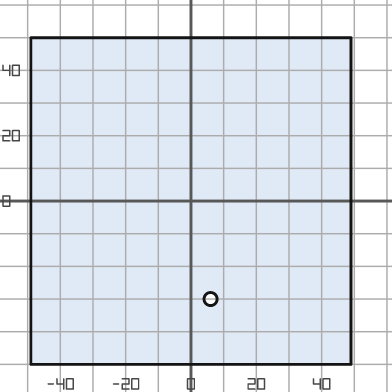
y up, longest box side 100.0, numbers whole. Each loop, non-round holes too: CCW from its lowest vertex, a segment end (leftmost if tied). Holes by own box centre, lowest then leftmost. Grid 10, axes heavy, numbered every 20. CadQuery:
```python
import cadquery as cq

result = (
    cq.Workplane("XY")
    .moveTo(-49.0, -50.0)
    .lineTo(49.0, -50.0)
    .lineTo(49.0, 50.0)
    .lineTo(-49.0, 50.0)
    .close()
    .moveTo(6.0, -30.0)
    .circle(2.0)
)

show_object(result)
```